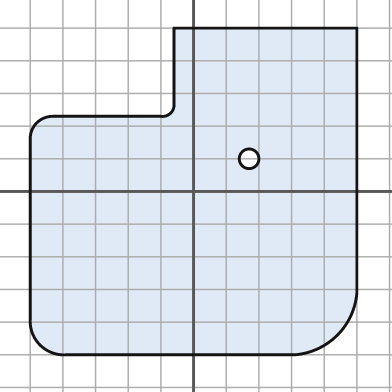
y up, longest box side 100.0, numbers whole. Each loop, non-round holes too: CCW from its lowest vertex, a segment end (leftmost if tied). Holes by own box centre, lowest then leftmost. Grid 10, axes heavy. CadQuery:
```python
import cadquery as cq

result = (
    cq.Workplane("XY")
    .moveTo(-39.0, -50.0)
    .lineTo(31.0, -50.0)
    .threePointArc((44.0, -44.0), (50.0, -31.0))
    .lineTo(50.0, 50.0)
    .lineTo(-6.0, 50.0)
    .lineTo(-6.0, 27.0)
    .threePointArc((-7.0, 24.0), (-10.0, 23.0))
    .lineTo(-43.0, 23.0)
    .threePointArc((-48.0, 21.0), (-50.0, 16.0))
    .lineTo(-50.0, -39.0)
    .threePointArc((-47.0, -47.0), (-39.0, -50.0))
    .close()
    .moveTo(17.0, 10.0)
    .circle(3.0)
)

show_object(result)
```